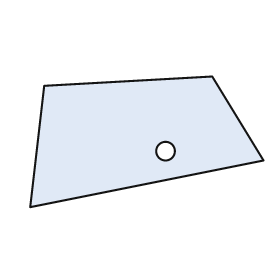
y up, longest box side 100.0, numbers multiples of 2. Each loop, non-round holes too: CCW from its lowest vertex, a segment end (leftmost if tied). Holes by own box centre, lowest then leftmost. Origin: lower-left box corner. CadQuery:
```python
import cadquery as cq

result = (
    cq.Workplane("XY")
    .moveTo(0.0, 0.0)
    .lineTo(100.0, 20.0)
    .lineTo(78.0, 56.0)
    .lineTo(6.0, 52.0)
    .close()
    .moveTo(58.0, 24.0)
    .circle(4.0)
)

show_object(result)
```